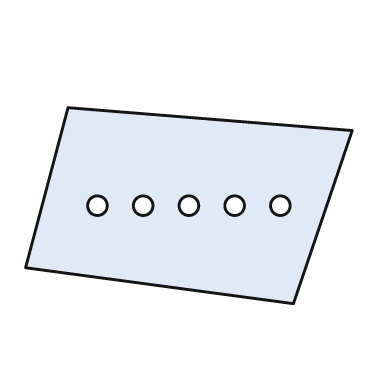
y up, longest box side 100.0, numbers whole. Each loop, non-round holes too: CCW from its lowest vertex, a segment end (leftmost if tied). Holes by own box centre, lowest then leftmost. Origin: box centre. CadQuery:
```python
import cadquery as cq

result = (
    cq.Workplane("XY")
    .moveTo(32.0, -30.0)
    .lineTo(50.0, 23.0)
    .lineTo(-37.0, 30.0)
    .lineTo(-50.0, -19.0)
    .close()
    .moveTo(-28.0, 0.0)
    .circle(3.0)
    .moveTo(-14.0, 0.0)
    .circle(3.0)
    .moveTo(0.0, 0.0)
    .circle(3.0)
    .moveTo(14.0, 0.0)
    .circle(3.0)
    .moveTo(28.0, 0.0)
    .circle(3.0)
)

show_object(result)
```